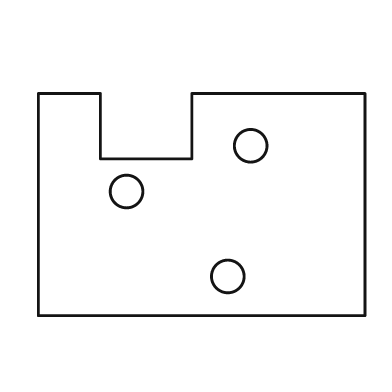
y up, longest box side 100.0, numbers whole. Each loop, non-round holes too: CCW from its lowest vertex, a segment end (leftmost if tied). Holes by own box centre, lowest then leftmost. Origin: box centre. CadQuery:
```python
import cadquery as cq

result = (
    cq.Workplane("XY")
    .moveTo(-50.0, -34.0)
    .lineTo(50.0, -34.0)
    .lineTo(50.0, 34.0)
    .lineTo(-3.0, 34.0)
    .lineTo(-3.0, 14.0)
    .lineTo(-31.0, 14.0)
    .lineTo(-31.0, 34.0)
    .lineTo(-50.0, 34.0)
    .close()
    .moveTo(8.0, -22.0)
    .circle(5.0)
    .moveTo(-23.0, 4.0)
    .circle(5.0)
    .moveTo(15.0, 18.0)
    .circle(5.0)
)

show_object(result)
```